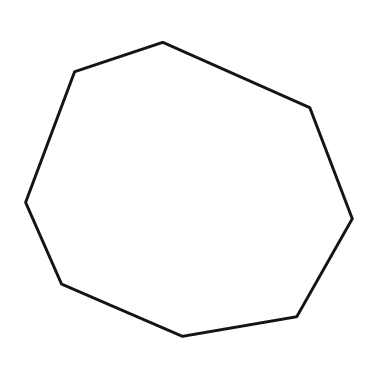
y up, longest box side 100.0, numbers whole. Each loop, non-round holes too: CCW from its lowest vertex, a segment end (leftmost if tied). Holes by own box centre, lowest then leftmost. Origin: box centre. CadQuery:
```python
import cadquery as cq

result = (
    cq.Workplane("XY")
    .moveTo(-2.0, -45.0)
    .lineTo(33.0, -39.0)
    .lineTo(50.0, -9.0)
    .lineTo(37.0, 25.0)
    .lineTo(-8.0, 45.0)
    .lineTo(-35.0, 36.0)
    .lineTo(-50.0, -4.0)
    .lineTo(-39.0, -29.0)
    .close()
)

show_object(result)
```